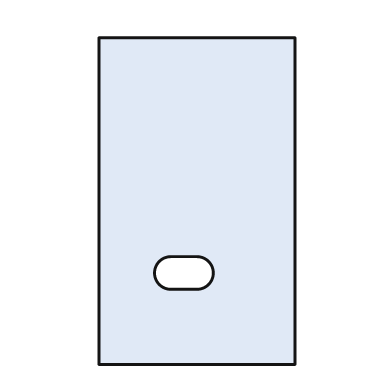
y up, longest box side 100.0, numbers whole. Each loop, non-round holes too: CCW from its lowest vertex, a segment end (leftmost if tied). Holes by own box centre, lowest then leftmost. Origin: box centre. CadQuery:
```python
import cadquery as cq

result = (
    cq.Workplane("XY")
    .moveTo(-30.0, -50.0)
    .lineTo(30.0, -50.0)
    .lineTo(30.0, 50.0)
    .lineTo(-30.0, 50.0)
    .close()
    .moveTo(-8.0, -27.0)
    .lineTo(0.0, -27.0)
    .threePointArc((5.0, -22.0), (0.0, -17.0))
    .lineTo(-8.0, -17.0)
    .threePointArc((-13.0, -22.0), (-8.0, -27.0))
    .close()
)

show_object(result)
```